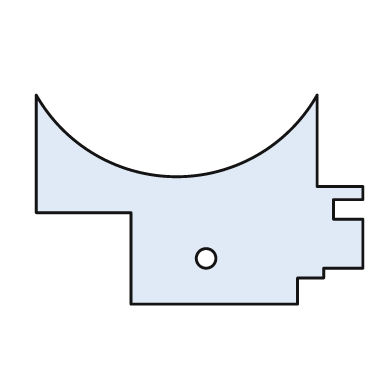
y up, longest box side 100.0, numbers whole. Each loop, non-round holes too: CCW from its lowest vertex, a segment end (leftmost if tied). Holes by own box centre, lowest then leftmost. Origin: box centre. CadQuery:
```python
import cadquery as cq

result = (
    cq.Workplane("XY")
    .moveTo(-21.0, -32.0)
    .lineTo(30.0, -32.0)
    .lineTo(30.0, -24.0)
    .lineTo(38.0, -24.0)
    .lineTo(38.0, -21.0)
    .lineTo(50.0, -21.0)
    .lineTo(50.0, -6.0)
    .lineTo(41.0, -6.0)
    .lineTo(41.0, 0.0)
    .lineTo(50.0, 0.0)
    .lineTo(50.0, 4.0)
    .lineTo(36.0, 4.0)
    .lineTo(36.0, 32.0)
    .threePointArc((-7.0, 7.0), (-50.0, 32.0))
    .lineTo(-50.0, -4.0)
    .lineTo(-21.0, -4.0)
    .close()
    .moveTo(2.0, -18.0)
    .circle(3.0)
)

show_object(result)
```